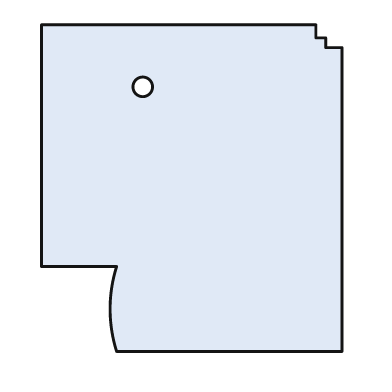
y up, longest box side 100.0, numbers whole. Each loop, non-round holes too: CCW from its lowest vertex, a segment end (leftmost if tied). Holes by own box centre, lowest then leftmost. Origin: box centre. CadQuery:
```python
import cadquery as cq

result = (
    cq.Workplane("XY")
    .moveTo(-23.0, -50.0)
    .lineTo(46.0, -50.0)
    .lineTo(46.0, 43.0)
    .lineTo(41.0, 43.0)
    .lineTo(41.0, 46.0)
    .lineTo(38.0, 46.0)
    .lineTo(38.0, 50.0)
    .lineTo(-46.0, 50.0)
    .lineTo(-46.0, -24.0)
    .lineTo(-23.0, -24.0)
    .threePointArc((-25.0, -37.0), (-23.0, -50.0))
    .close()
    .moveTo(-15.0, 31.0)
    .circle(3.0)
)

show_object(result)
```